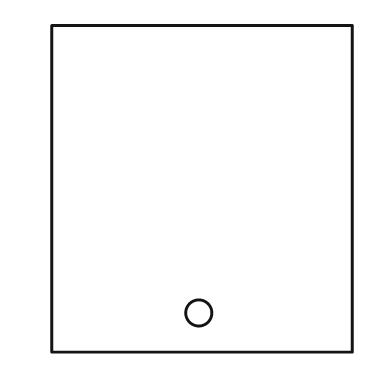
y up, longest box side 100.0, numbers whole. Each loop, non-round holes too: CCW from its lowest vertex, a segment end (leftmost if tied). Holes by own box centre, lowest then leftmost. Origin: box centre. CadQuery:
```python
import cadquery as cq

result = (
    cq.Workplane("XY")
    .moveTo(-46.0, -50.0)
    .lineTo(46.0, -50.0)
    .lineTo(46.0, 50.0)
    .lineTo(-46.0, 50.0)
    .close()
    .moveTo(-1.0, -38.0)
    .circle(4.0)
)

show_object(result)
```